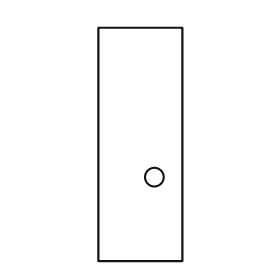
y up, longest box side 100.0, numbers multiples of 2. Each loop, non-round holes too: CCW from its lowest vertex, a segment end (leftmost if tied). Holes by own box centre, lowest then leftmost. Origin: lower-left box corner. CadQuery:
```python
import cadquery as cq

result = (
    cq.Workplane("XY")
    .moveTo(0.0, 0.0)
    .lineTo(36.0, 0.0)
    .lineTo(36.0, 100.0)
    .lineTo(0.0, 100.0)
    .close()
    .moveTo(24.0, 36.0)
    .circle(4.0)
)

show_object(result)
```